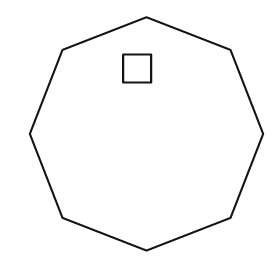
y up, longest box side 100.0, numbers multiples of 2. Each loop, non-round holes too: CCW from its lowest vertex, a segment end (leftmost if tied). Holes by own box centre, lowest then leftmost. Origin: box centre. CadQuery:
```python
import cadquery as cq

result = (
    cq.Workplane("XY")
    .moveTo(0.0, -50.0)
    .lineTo(36.0, -36.0)
    .lineTo(50.0, 0.0)
    .lineTo(36.0, 36.0)
    .lineTo(0.0, 50.0)
    .lineTo(-36.0, 36.0)
    .lineTo(-50.0, 0.0)
    .lineTo(-36.0, -36.0)
    .close()
    .moveTo(-10.0, 22.0)
    .lineTo(2.0, 22.0)
    .lineTo(2.0, 34.0)
    .lineTo(-10.0, 34.0)
    .close()
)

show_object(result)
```